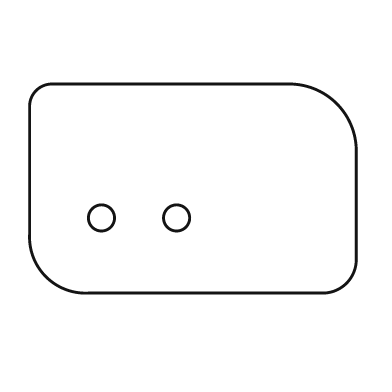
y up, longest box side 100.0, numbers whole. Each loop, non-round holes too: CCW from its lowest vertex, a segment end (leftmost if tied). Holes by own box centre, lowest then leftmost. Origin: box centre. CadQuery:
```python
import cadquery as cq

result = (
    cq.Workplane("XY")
    .moveTo(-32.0, -32.0)
    .lineTo(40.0, -32.0)
    .threePointArc((47.0, -29.0), (50.0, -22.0))
    .lineTo(50.0, 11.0)
    .threePointArc((44.0, 26.0), (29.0, 32.0))
    .lineTo(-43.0, 32.0)
    .threePointArc((-48.0, 30.0), (-50.0, 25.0))
    .lineTo(-50.0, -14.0)
    .threePointArc((-45.0, -27.0), (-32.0, -32.0))
    .close()
    .moveTo(-28.0, -9.0)
    .circle(4.0)
    .moveTo(-5.0, -9.0)
    .circle(4.0)
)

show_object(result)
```